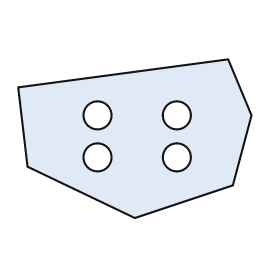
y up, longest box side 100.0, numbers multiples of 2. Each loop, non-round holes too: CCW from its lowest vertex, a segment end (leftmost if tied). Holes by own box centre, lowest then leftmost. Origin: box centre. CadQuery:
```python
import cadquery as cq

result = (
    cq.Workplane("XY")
    .moveTo(0.0, -34.0)
    .lineTo(42.0, -20.0)
    .lineTo(50.0, 10.0)
    .lineTo(40.0, 34.0)
    .lineTo(-50.0, 22.0)
    .lineTo(-46.0, -12.0)
    .close()
    .moveTo(-16.0, -8.0)
    .circle(6.0)
    .moveTo(18.0, -8.0)
    .circle(6.0)
    .moveTo(-16.0, 10.0)
    .circle(6.0)
    .moveTo(18.0, 10.0)
    .circle(6.0)
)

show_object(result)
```